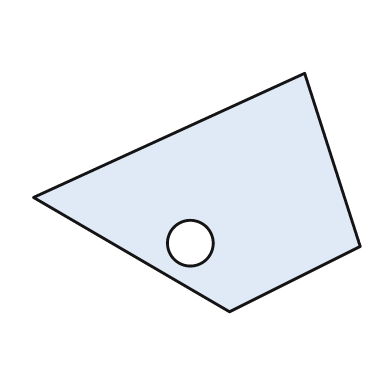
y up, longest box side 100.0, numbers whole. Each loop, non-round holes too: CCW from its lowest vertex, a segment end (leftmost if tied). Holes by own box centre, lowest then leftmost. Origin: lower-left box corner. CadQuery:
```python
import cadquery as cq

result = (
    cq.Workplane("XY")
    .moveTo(60.0, 0.0)
    .lineTo(100.0, 20.0)
    .lineTo(83.0, 73.0)
    .lineTo(0.0, 35.0)
    .close()
    .moveTo(48.0, 21.0)
    .circle(7.0)
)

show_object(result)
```